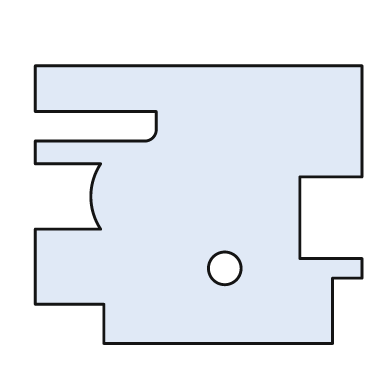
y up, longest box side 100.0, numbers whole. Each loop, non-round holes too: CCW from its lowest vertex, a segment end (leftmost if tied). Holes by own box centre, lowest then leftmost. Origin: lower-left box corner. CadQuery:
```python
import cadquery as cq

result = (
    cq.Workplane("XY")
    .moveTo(21.0, 0.0)
    .lineTo(91.0, 0.0)
    .lineTo(91.0, 20.0)
    .lineTo(100.0, 20.0)
    .lineTo(100.0, 26.0)
    .lineTo(81.0, 26.0)
    .lineTo(81.0, 51.0)
    .lineTo(100.0, 51.0)
    .lineTo(100.0, 85.0)
    .lineTo(0.0, 85.0)
    .lineTo(0.0, 71.0)
    .lineTo(37.0, 71.0)
    .lineTo(37.0, 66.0)
    .threePointArc((36.0, 63.0), (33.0, 62.0))
    .lineTo(0.0, 62.0)
    .lineTo(0.0, 55.0)
    .lineTo(20.0, 55.0)
    .threePointArc((17.0, 45.0), (20.0, 35.0))
    .lineTo(0.0, 35.0)
    .lineTo(0.0, 12.0)
    .lineTo(21.0, 12.0)
    .close()
    .moveTo(58.0, 23.0)
    .circle(5.0)
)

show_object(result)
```